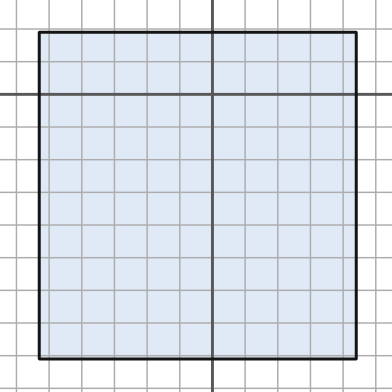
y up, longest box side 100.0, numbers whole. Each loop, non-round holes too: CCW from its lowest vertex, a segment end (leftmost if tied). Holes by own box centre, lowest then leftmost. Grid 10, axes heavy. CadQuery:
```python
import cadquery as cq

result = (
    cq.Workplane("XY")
    .moveTo(-53.0, -81.0)
    .lineTo(44.0, -81.0)
    .lineTo(44.0, 19.0)
    .lineTo(-53.0, 19.0)
    .close()
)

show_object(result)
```